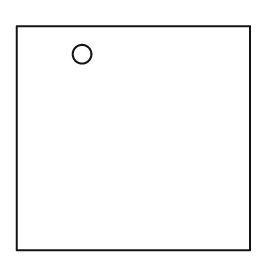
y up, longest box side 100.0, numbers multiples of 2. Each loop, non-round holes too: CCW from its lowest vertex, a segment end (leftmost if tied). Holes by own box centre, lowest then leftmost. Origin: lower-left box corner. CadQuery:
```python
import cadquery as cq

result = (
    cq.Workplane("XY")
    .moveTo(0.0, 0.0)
    .lineTo(100.0, 0.0)
    .lineTo(100.0, 96.0)
    .lineTo(0.0, 96.0)
    .close()
    .moveTo(28.0, 84.0)
    .circle(4.0)
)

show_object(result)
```